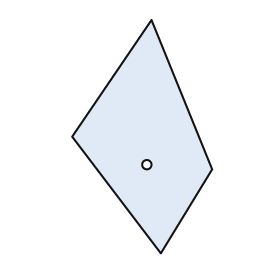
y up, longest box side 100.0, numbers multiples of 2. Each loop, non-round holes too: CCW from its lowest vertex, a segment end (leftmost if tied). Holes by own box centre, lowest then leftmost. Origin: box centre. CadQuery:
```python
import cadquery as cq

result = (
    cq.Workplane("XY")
    .moveTo(8.0, -50.0)
    .lineTo(30.0, -14.0)
    .lineTo(4.0, 50.0)
    .lineTo(-30.0, 0.0)
    .close()
    .moveTo(2.0, -12.0)
    .circle(2.0)
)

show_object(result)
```